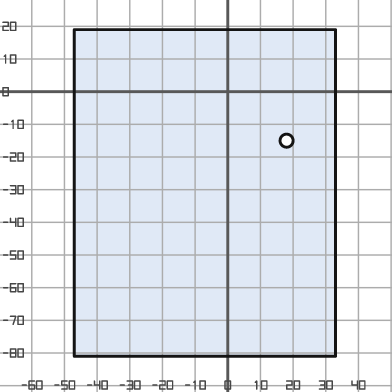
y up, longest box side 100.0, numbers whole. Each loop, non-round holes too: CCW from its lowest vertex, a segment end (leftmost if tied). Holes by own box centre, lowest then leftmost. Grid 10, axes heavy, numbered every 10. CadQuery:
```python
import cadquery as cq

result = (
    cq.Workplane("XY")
    .moveTo(-47.0, -81.0)
    .lineTo(33.0, -81.0)
    .lineTo(33.0, 19.0)
    .lineTo(-47.0, 19.0)
    .close()
    .moveTo(18.0, -15.0)
    .circle(2.0)
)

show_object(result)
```